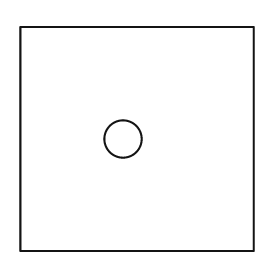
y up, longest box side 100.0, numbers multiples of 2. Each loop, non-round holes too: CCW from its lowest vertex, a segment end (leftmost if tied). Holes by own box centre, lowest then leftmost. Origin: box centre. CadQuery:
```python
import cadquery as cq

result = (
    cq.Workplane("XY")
    .moveTo(-50.0, -48.0)
    .lineTo(50.0, -48.0)
    .lineTo(50.0, 48.0)
    .lineTo(-50.0, 48.0)
    .close()
    .moveTo(-6.0, 0.0)
    .circle(8.0)
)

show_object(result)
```